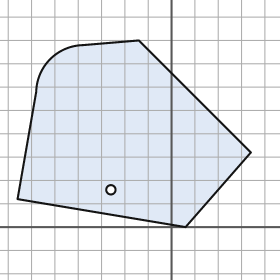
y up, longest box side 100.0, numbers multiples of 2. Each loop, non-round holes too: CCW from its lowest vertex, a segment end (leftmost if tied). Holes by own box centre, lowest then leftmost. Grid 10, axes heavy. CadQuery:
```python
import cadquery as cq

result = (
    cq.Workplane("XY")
    .moveTo(6.0, 0.0)
    .lineTo(34.0, 32.0)
    .lineTo(-14.0, 80.0)
    .lineTo(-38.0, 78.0)
    .threePointArc((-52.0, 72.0), (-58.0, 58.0))
    .lineTo(-66.0, 12.0)
    .close()
    .moveTo(-26.0, 16.0)
    .circle(2.0)
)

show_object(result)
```